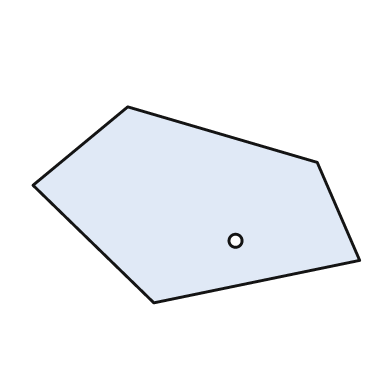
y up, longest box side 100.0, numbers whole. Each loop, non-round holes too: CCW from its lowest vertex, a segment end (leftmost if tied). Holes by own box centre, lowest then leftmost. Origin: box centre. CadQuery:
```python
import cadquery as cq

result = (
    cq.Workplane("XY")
    .moveTo(-13.0, -30.0)
    .lineTo(50.0, -17.0)
    .lineTo(37.0, 13.0)
    .lineTo(-21.0, 30.0)
    .lineTo(-50.0, 6.0)
    .close()
    .moveTo(12.0, -11.0)
    .circle(2.0)
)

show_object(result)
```